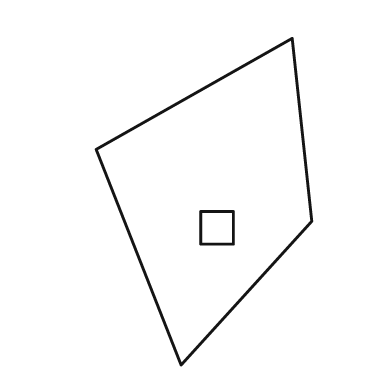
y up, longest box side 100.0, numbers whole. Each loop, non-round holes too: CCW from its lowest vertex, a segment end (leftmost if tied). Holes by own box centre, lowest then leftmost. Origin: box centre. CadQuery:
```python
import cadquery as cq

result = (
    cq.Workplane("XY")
    .moveTo(-7.0, -50.0)
    .lineTo(33.0, -6.0)
    .lineTo(27.0, 50.0)
    .lineTo(-33.0, 16.0)
    .close()
    .moveTo(-1.0, -13.0)
    .lineTo(9.0, -13.0)
    .lineTo(9.0, -3.0)
    .lineTo(-1.0, -3.0)
    .close()
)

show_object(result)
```